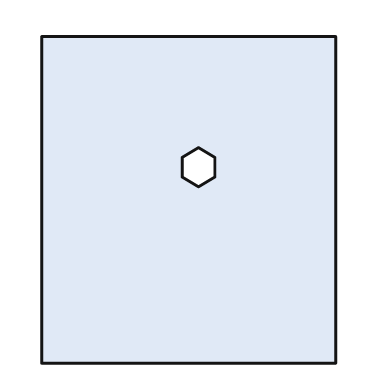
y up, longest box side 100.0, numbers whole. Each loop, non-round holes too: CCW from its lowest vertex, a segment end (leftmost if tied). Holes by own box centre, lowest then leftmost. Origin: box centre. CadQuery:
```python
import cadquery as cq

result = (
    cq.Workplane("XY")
    .moveTo(-45.0, -50.0)
    .lineTo(45.0, -50.0)
    .lineTo(45.0, 50.0)
    .lineTo(-45.0, 50.0)
    .close()
    .moveTo(3.0, 4.0)
    .lineTo(8.0, 7.0)
    .lineTo(8.0, 13.0)
    .lineTo(3.0, 16.0)
    .lineTo(-2.0, 13.0)
    .lineTo(-2.0, 7.0)
    .close()
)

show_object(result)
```